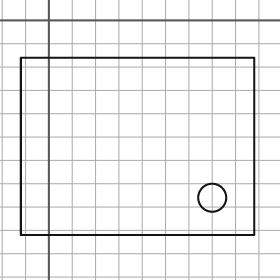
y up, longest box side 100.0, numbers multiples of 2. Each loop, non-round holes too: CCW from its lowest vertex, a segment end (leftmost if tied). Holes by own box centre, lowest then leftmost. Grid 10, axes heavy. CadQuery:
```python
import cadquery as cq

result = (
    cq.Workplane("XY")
    .moveTo(-12.0, -92.0)
    .lineTo(88.0, -92.0)
    .lineTo(88.0, -16.0)
    .lineTo(-12.0, -16.0)
    .close()
    .moveTo(70.0, -76.0)
    .circle(6.0)
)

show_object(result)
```